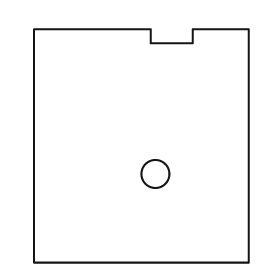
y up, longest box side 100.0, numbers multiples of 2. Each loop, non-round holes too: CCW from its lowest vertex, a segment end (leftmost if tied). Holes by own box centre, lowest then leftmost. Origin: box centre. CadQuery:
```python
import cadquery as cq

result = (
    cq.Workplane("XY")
    .moveTo(-46.0, -50.0)
    .lineTo(46.0, -50.0)
    .lineTo(46.0, 50.0)
    .lineTo(22.0, 50.0)
    .lineTo(22.0, 44.0)
    .lineTo(4.0, 44.0)
    .lineTo(4.0, 50.0)
    .lineTo(-46.0, 50.0)
    .close()
    .moveTo(6.0, -12.0)
    .circle(6.0)
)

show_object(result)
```